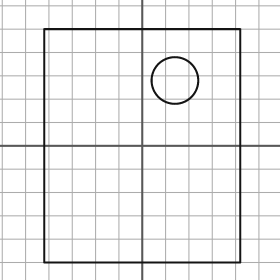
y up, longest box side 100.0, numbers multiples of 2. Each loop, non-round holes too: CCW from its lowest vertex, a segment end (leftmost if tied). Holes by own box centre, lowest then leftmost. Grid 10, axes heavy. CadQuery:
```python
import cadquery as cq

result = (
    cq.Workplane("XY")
    .moveTo(-42.0, -50.0)
    .lineTo(42.0, -50.0)
    .lineTo(42.0, 50.0)
    .lineTo(-42.0, 50.0)
    .close()
    .moveTo(14.0, 28.0)
    .circle(10.0)
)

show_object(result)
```